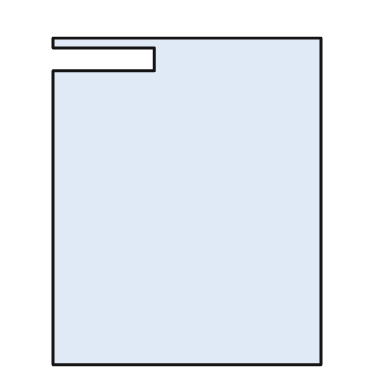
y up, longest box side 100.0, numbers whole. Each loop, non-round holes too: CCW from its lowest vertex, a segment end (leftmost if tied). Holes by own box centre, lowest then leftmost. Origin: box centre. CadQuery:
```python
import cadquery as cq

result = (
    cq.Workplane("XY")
    .moveTo(-41.0, -50.0)
    .lineTo(41.0, -50.0)
    .lineTo(41.0, 50.0)
    .lineTo(-41.0, 50.0)
    .lineTo(-41.0, 47.0)
    .lineTo(-10.0, 47.0)
    .lineTo(-10.0, 40.0)
    .lineTo(-41.0, 40.0)
    .close()
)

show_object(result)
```